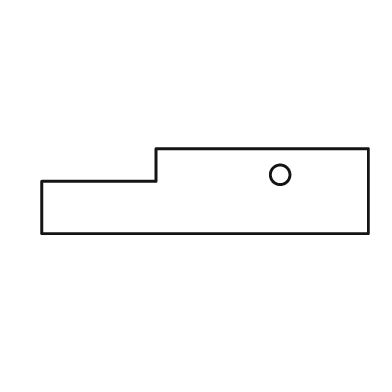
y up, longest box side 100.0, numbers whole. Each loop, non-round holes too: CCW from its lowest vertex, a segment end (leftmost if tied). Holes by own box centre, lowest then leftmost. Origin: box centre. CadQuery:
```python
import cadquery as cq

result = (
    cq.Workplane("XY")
    .moveTo(-50.0, -13.0)
    .lineTo(50.0, -13.0)
    .lineTo(50.0, 13.0)
    .lineTo(-15.0, 13.0)
    .lineTo(-15.0, 3.0)
    .lineTo(-50.0, 3.0)
    .close()
    .moveTo(23.0, 5.0)
    .circle(3.0)
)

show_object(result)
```